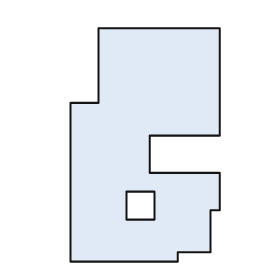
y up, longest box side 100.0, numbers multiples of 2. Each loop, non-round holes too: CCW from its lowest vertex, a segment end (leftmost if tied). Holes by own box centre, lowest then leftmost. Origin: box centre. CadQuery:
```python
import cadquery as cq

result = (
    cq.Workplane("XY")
    .moveTo(-32.0, -50.0)
    .lineTo(14.0, -50.0)
    .lineTo(14.0, -46.0)
    .lineTo(28.0, -46.0)
    .lineTo(28.0, -28.0)
    .lineTo(32.0, -28.0)
    .lineTo(32.0, -12.0)
    .lineTo(2.0, -12.0)
    .lineTo(2.0, 4.0)
    .lineTo(32.0, 4.0)
    .lineTo(32.0, 50.0)
    .lineTo(-20.0, 50.0)
    .lineTo(-20.0, 18.0)
    .lineTo(-32.0, 18.0)
    .close()
    .moveTo(-8.0, -32.0)
    .lineTo(4.0, -32.0)
    .lineTo(4.0, -20.0)
    .lineTo(-8.0, -20.0)
    .close()
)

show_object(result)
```